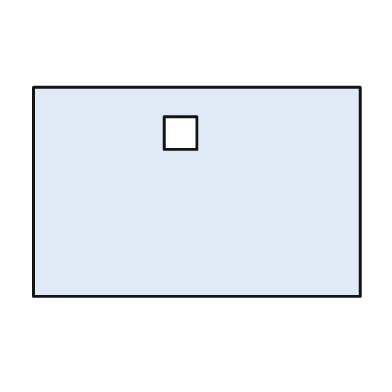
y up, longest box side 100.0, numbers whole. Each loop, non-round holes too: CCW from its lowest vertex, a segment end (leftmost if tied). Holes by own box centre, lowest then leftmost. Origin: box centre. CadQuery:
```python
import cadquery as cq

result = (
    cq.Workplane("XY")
    .moveTo(-50.0, -32.0)
    .lineTo(50.0, -32.0)
    .lineTo(50.0, 32.0)
    .lineTo(-50.0, 32.0)
    .close()
    .moveTo(-10.0, 13.0)
    .lineTo(0.0, 13.0)
    .lineTo(0.0, 23.0)
    .lineTo(-10.0, 23.0)
    .close()
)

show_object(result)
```